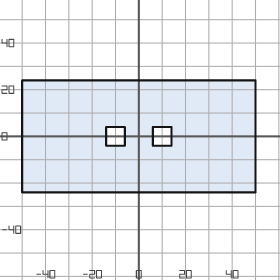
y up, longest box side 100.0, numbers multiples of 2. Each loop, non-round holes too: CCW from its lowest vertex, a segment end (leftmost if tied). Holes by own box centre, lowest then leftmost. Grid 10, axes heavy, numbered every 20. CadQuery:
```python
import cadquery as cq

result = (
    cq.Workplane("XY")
    .moveTo(-50.0, -24.0)
    .lineTo(50.0, -24.0)
    .lineTo(50.0, 24.0)
    .lineTo(-50.0, 24.0)
    .close()
    .moveTo(-14.0, -4.0)
    .lineTo(-6.0, -4.0)
    .lineTo(-6.0, 4.0)
    .lineTo(-14.0, 4.0)
    .close()
    .moveTo(6.0, -4.0)
    .lineTo(14.0, -4.0)
    .lineTo(14.0, 4.0)
    .lineTo(6.0, 4.0)
    .close()
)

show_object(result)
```